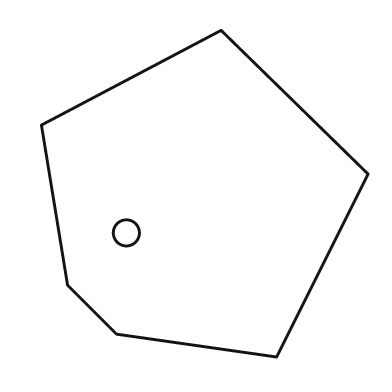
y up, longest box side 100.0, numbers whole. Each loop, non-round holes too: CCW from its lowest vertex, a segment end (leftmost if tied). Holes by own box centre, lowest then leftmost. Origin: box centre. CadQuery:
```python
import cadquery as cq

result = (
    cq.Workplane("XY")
    .moveTo(22.0, -50.0)
    .lineTo(50.0, 6.0)
    .lineTo(5.0, 50.0)
    .lineTo(-50.0, 21.0)
    .lineTo(-42.0, -28.0)
    .lineTo(-27.0, -43.0)
    .close()
    .moveTo(-24.0, -12.0)
    .circle(4.0)
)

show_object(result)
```